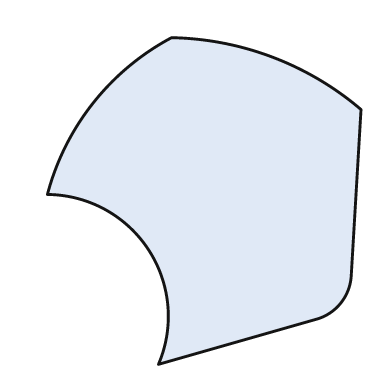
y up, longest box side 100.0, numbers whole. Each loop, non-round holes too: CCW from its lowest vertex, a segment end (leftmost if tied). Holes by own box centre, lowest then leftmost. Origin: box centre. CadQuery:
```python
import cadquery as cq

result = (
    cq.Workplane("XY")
    .moveTo(-14.0, -50.0)
    .lineTo(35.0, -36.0)
    .threePointArc((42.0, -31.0), (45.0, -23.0))
    .lineTo(48.0, 28.0)
    .threePointArc((21.0, 44.0), (-10.0, 50.0))
    .threePointArc((-34.0, 30.0), (-48.0, 2.0))
    .threePointArc((-17.0, -15.0), (-14.0, -50.0))
    .close()
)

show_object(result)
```